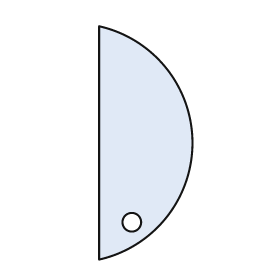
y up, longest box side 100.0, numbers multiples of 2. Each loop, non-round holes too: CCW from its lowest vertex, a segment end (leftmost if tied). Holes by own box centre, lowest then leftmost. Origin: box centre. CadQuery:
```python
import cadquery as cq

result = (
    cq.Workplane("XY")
    .moveTo(-20.0, -50.0)
    .threePointArc((20.0, 0.0), (-20.0, 50.0))
    .close()
    .moveTo(-6.0, -34.0)
    .circle(4.0)
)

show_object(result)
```